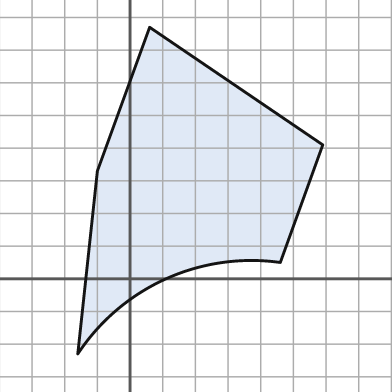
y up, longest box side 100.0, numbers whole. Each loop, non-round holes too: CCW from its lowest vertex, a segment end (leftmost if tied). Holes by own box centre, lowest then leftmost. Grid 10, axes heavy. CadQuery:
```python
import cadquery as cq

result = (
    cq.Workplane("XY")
    .moveTo(-16.0, -23.0)
    .threePointArc((11.0, 0.0), (46.0, 5.0))
    .lineTo(59.0, 41.0)
    .lineTo(6.0, 77.0)
    .lineTo(-10.0, 33.0)
    .close()
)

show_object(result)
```